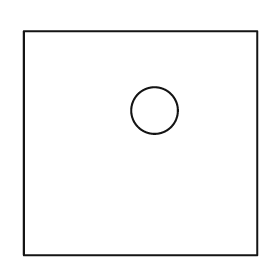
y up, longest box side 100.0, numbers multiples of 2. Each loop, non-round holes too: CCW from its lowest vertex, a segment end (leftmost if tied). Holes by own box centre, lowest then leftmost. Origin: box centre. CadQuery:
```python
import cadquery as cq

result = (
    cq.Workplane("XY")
    .moveTo(-50.0, -48.0)
    .lineTo(50.0, -48.0)
    .lineTo(50.0, 48.0)
    .lineTo(-50.0, 48.0)
    .close()
    .moveTo(6.0, 14.0)
    .circle(10.0)
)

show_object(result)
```